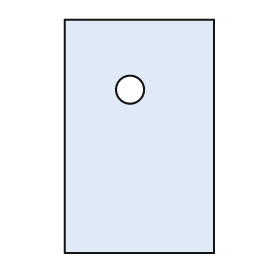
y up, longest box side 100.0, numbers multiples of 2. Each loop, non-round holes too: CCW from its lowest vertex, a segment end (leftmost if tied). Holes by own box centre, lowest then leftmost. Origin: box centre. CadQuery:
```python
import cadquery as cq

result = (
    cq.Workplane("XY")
    .moveTo(-32.0, -50.0)
    .lineTo(32.0, -50.0)
    .lineTo(32.0, 50.0)
    .lineTo(-32.0, 50.0)
    .close()
    .moveTo(-4.0, 20.0)
    .circle(6.0)
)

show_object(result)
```